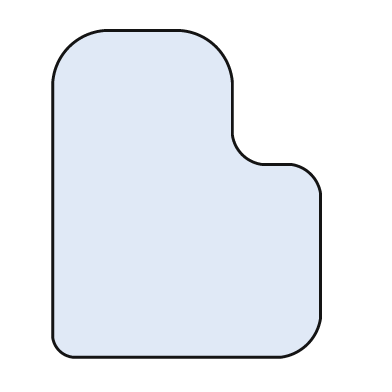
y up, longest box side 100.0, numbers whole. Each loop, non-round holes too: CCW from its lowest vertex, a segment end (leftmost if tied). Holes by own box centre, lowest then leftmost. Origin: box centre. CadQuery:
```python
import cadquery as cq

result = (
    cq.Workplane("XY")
    .moveTo(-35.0, -50.0)
    .lineTo(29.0, -50.0)
    .threePointArc((37.0, -46.0), (41.0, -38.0))
    .lineTo(41.0, 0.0)
    .threePointArc((38.0, 6.0), (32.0, 9.0))
    .lineTo(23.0, 9.0)
    .threePointArc((17.0, 12.0), (14.0, 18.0))
    .lineTo(14.0, 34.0)
    .threePointArc((9.0, 45.0), (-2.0, 50.0))
    .lineTo(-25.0, 50.0)
    .threePointArc((-36.0, 45.0), (-41.0, 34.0))
    .lineTo(-41.0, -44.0)
    .threePointArc((-39.0, -48.0), (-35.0, -50.0))
    .close()
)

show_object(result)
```